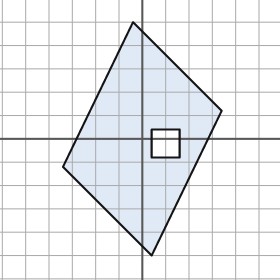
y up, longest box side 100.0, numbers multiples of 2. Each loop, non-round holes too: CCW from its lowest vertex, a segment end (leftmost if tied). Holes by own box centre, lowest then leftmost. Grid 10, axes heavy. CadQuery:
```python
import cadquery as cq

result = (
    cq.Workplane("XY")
    .moveTo(4.0, -50.0)
    .lineTo(34.0, 12.0)
    .lineTo(-4.0, 50.0)
    .lineTo(-34.0, -12.0)
    .close()
    .moveTo(4.0, -8.0)
    .lineTo(16.0, -8.0)
    .lineTo(16.0, 4.0)
    .lineTo(4.0, 4.0)
    .close()
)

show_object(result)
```